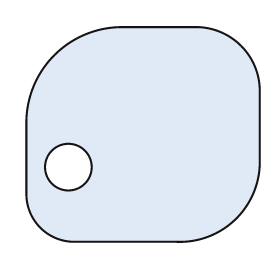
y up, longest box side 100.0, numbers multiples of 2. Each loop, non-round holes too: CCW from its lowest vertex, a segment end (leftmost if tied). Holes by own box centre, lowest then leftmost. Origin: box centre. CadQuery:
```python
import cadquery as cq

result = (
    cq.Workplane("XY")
    .moveTo(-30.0, -46.0)
    .lineTo(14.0, -46.0)
    .threePointArc((40.0, -36.0), (50.0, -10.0))
    .lineTo(50.0, 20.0)
    .threePointArc((42.0, 38.0), (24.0, 46.0))
    .lineTo(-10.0, 46.0)
    .threePointArc((-38.0, 34.0), (-50.0, 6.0))
    .lineTo(-50.0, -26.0)
    .threePointArc((-44.0, -40.0), (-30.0, -46.0))
    .close()
    .moveTo(-32.0, -14.0)
    .circle(10.0)
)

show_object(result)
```